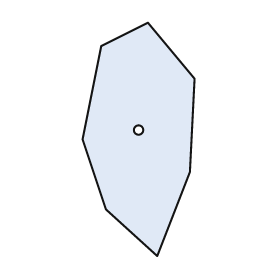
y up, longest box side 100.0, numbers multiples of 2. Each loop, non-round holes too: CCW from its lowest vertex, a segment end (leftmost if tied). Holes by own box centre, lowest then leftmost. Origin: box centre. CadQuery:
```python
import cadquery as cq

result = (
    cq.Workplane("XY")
    .moveTo(8.0, -50.0)
    .lineTo(22.0, -14.0)
    .lineTo(24.0, 26.0)
    .lineTo(4.0, 50.0)
    .lineTo(-16.0, 40.0)
    .lineTo(-24.0, 0.0)
    .lineTo(-14.0, -30.0)
    .close()
    .moveTo(0.0, 4.0)
    .circle(2.0)
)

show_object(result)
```